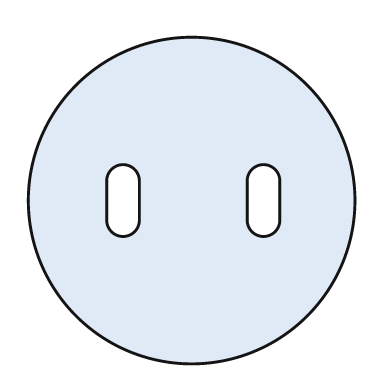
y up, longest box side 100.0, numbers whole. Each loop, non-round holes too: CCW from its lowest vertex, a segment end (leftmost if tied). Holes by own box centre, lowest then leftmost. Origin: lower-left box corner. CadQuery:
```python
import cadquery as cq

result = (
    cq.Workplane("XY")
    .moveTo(50.0, 50.0)
    .circle(50.0)
    .moveTo(24.0, 44.0)
    .threePointArc((29.0, 39.0), (34.0, 44.0))
    .lineTo(34.0, 56.0)
    .threePointArc((29.0, 61.0), (24.0, 56.0))
    .close()
    .moveTo(67.0, 44.0)
    .threePointArc((72.0, 39.0), (77.0, 44.0))
    .lineTo(77.0, 56.0)
    .threePointArc((72.0, 61.0), (67.0, 56.0))
    .close()
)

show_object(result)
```